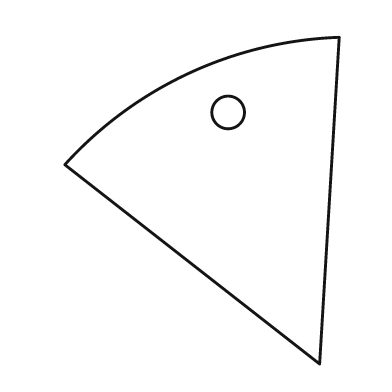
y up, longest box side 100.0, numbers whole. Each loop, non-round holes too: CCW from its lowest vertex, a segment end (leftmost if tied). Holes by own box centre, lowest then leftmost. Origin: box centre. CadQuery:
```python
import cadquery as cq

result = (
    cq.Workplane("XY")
    .moveTo(36.0, -50.0)
    .lineTo(42.0, 50.0)
    .threePointArc((-4.0, 39.0), (-42.0, 11.0))
    .close()
    .moveTo(8.0, 27.0)
    .circle(5.0)
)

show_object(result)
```